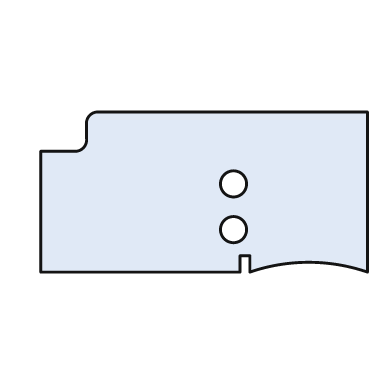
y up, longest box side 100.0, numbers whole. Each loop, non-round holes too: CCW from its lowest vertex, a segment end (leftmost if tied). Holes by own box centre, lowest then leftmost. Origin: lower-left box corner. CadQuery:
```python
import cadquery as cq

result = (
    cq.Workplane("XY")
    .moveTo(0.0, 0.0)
    .lineTo(61.0, 0.0)
    .lineTo(61.0, 5.0)
    .lineTo(64.0, 5.0)
    .lineTo(64.0, 0.0)
    .threePointArc((82.0, 3.0), (100.0, 0.0))
    .lineTo(100.0, 49.0)
    .lineTo(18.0, 49.0)
    .threePointArc((15.0, 48.0), (14.0, 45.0))
    .lineTo(14.0, 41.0)
    .threePointArc((13.0, 38.0), (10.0, 37.0))
    .lineTo(0.0, 37.0)
    .close()
    .moveTo(59.0, 13.0)
    .circle(4.0)
    .moveTo(59.0, 27.0)
    .circle(4.0)
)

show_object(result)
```